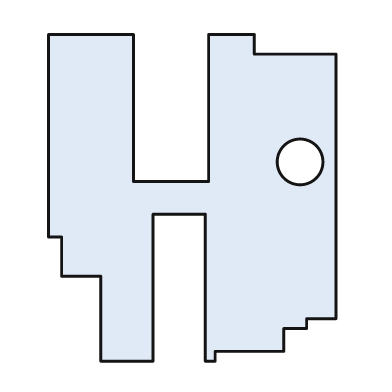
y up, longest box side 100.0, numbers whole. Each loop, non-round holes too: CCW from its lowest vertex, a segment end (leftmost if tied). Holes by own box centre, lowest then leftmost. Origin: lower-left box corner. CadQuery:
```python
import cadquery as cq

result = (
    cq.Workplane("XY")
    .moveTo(16.0, 0.0)
    .lineTo(32.0, 0.0)
    .lineTo(32.0, 45.0)
    .lineTo(48.0, 45.0)
    .lineTo(48.0, 0.0)
    .lineTo(51.0, 0.0)
    .lineTo(51.0, 3.0)
    .lineTo(72.0, 3.0)
    .lineTo(72.0, 10.0)
    .lineTo(79.0, 10.0)
    .lineTo(79.0, 13.0)
    .lineTo(88.0, 13.0)
    .lineTo(88.0, 94.0)
    .lineTo(63.0, 94.0)
    .lineTo(63.0, 100.0)
    .lineTo(49.0, 100.0)
    .lineTo(49.0, 55.0)
    .lineTo(26.0, 55.0)
    .lineTo(26.0, 100.0)
    .lineTo(0.0, 100.0)
    .lineTo(0.0, 38.0)
    .lineTo(4.0, 38.0)
    .lineTo(4.0, 26.0)
    .lineTo(16.0, 26.0)
    .close()
    .moveTo(77.0, 61.0)
    .circle(7.0)
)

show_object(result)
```